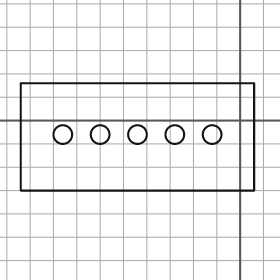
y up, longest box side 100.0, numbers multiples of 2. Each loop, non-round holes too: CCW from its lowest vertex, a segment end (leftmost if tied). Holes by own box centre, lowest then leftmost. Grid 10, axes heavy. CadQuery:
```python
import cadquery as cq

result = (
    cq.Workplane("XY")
    .moveTo(-94.0, -30.0)
    .lineTo(6.0, -30.0)
    .lineTo(6.0, 16.0)
    .lineTo(-94.0, 16.0)
    .close()
    .moveTo(-76.0, -6.0)
    .circle(4.0)
    .moveTo(-60.0, -6.0)
    .circle(4.0)
    .moveTo(-44.0, -6.0)
    .circle(4.0)
    .moveTo(-28.0, -6.0)
    .circle(4.0)
    .moveTo(-12.0, -6.0)
    .circle(4.0)
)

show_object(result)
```